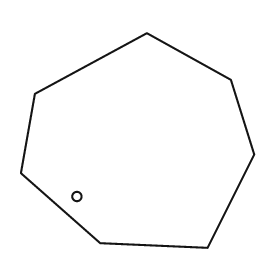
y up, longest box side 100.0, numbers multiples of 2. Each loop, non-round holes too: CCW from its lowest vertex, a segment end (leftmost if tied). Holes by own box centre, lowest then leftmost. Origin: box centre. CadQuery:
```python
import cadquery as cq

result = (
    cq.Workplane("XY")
    .moveTo(30.0, -46.0)
    .lineTo(50.0, -6.0)
    .lineTo(40.0, 26.0)
    .lineTo(4.0, 46.0)
    .lineTo(-44.0, 20.0)
    .lineTo(-50.0, -14.0)
    .lineTo(-16.0, -44.0)
    .close()
    .moveTo(-26.0, -24.0)
    .circle(2.0)
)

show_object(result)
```